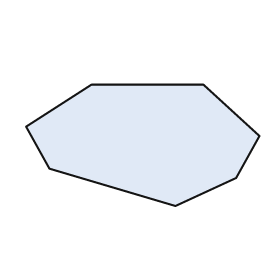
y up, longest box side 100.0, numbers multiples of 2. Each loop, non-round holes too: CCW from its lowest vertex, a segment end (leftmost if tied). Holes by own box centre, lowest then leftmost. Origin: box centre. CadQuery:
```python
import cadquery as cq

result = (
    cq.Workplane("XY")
    .moveTo(14.0, -26.0)
    .lineTo(40.0, -14.0)
    .lineTo(50.0, 4.0)
    .lineTo(26.0, 26.0)
    .lineTo(-22.0, 26.0)
    .lineTo(-50.0, 8.0)
    .lineTo(-40.0, -10.0)
    .close()
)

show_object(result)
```